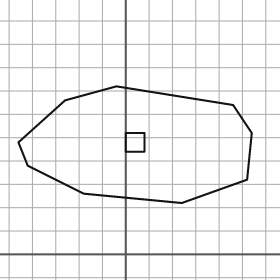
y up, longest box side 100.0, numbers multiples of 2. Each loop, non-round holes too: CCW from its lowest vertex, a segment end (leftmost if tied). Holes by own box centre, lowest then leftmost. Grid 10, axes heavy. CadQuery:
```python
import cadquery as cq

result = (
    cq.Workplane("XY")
    .moveTo(24.0, 22.0)
    .lineTo(52.0, 32.0)
    .lineTo(54.0, 52.0)
    .lineTo(46.0, 64.0)
    .lineTo(-4.0, 72.0)
    .lineTo(-26.0, 66.0)
    .lineTo(-46.0, 48.0)
    .lineTo(-42.0, 38.0)
    .lineTo(-18.0, 26.0)
    .close()
    .moveTo(0.0, 44.0)
    .lineTo(8.0, 44.0)
    .lineTo(8.0, 52.0)
    .lineTo(0.0, 52.0)
    .close()
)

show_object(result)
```